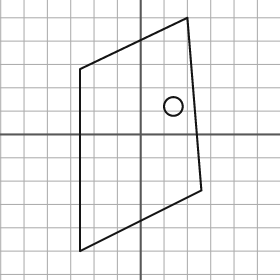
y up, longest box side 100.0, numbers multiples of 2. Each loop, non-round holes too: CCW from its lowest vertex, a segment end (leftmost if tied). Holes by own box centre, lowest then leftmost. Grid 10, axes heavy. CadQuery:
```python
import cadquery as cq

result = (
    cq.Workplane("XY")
    .moveTo(-26.0, -50.0)
    .lineTo(26.0, -24.0)
    .lineTo(20.0, 50.0)
    .lineTo(-26.0, 28.0)
    .close()
    .moveTo(14.0, 12.0)
    .circle(4.0)
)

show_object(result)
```